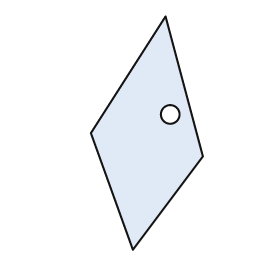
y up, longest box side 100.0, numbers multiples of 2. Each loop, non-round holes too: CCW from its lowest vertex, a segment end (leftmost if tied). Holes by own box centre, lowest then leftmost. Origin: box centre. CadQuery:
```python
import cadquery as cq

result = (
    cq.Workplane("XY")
    .moveTo(-6.0, -50.0)
    .lineTo(24.0, -10.0)
    .lineTo(8.0, 50.0)
    .lineTo(-24.0, 0.0)
    .close()
    .moveTo(10.0, 8.0)
    .circle(4.0)
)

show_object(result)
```